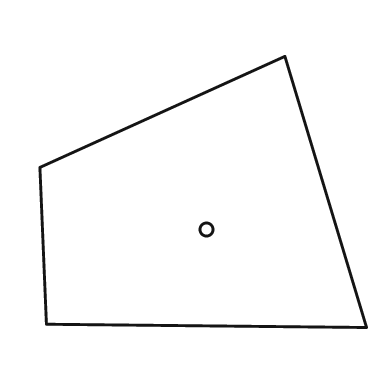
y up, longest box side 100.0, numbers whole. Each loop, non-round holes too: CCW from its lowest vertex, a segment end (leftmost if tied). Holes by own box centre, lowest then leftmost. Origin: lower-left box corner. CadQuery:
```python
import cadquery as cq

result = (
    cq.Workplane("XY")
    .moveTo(100.0, 0.0)
    .lineTo(75.0, 83.0)
    .lineTo(0.0, 49.0)
    .lineTo(2.0, 1.0)
    .close()
    .moveTo(51.0, 30.0)
    .circle(2.0)
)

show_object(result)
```